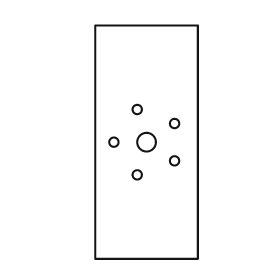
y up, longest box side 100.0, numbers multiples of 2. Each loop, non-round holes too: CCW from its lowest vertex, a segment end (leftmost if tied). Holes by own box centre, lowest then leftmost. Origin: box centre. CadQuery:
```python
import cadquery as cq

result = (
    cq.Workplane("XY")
    .moveTo(-22.0, -50.0)
    .lineTo(22.0, -50.0)
    .lineTo(22.0, 50.0)
    .lineTo(-22.0, 50.0)
    .close()
    .moveTo(-4.0, -14.0)
    .circle(2.0)
    .moveTo(12.0, -8.0)
    .circle(2.0)
    .moveTo(-14.0, 0.0)
    .circle(2.0)
    .moveTo(0.0, 0.0)
    .circle(4.0)
    .moveTo(12.0, 8.0)
    .circle(2.0)
    .moveTo(-4.0, 14.0)
    .circle(2.0)
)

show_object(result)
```